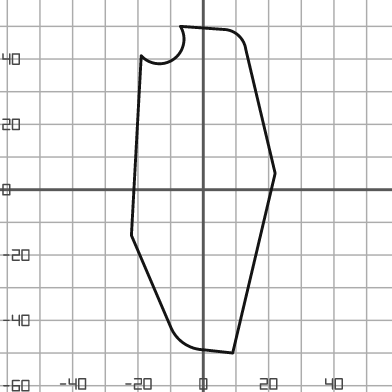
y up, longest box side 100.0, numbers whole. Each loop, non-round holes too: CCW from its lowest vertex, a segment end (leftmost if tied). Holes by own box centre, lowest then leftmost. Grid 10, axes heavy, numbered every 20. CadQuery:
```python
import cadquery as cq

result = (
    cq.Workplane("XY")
    .moveTo(9.0, -50.0)
    .lineTo(22.0, 5.0)
    .lineTo(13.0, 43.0)
    .threePointArc((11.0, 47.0), (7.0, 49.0))
    .lineTo(-7.0, 50.0)
    .threePointArc((-9.0, 40.0), (-19.0, 41.0))
    .lineTo(-22.0, -14.0)
    .lineTo(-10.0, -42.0)
    .threePointArc((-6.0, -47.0), (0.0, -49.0))
    .close()
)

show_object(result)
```